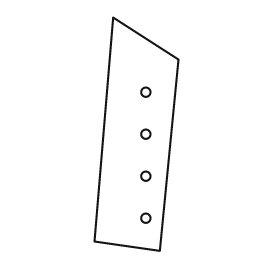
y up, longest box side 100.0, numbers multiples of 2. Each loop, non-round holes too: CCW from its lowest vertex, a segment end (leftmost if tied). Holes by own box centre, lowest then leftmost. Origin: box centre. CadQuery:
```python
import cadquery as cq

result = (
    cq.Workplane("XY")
    .moveTo(10.0, -50.0)
    .lineTo(18.0, 32.0)
    .lineTo(-10.0, 50.0)
    .lineTo(-18.0, -46.0)
    .close()
    .moveTo(4.0, -36.0)
    .circle(2.0)
    .moveTo(4.0, -18.0)
    .circle(2.0)
    .moveTo(4.0, 0.0)
    .circle(2.0)
    .moveTo(4.0, 18.0)
    .circle(2.0)
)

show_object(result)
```